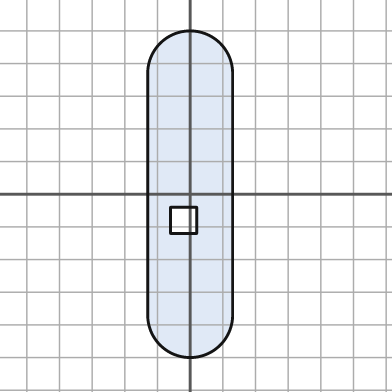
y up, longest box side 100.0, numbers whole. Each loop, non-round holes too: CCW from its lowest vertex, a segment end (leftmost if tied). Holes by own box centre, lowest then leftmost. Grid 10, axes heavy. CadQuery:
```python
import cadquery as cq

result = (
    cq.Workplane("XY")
    .moveTo(-13.0, -37.0)
    .threePointArc((0.0, -50.0), (13.0, -37.0))
    .lineTo(13.0, 37.0)
    .threePointArc((0.0, 50.0), (-13.0, 37.0))
    .close()
    .moveTo(-6.0, -12.0)
    .lineTo(2.0, -12.0)
    .lineTo(2.0, -4.0)
    .lineTo(-6.0, -4.0)
    .close()
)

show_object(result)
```